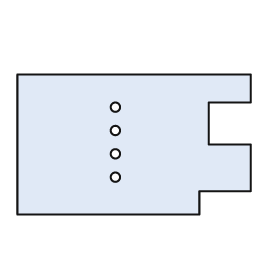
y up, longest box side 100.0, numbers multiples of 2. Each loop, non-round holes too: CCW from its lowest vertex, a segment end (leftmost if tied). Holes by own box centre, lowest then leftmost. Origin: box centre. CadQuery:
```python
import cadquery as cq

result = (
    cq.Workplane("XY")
    .moveTo(-50.0, -30.0)
    .lineTo(28.0, -30.0)
    .lineTo(28.0, -20.0)
    .lineTo(50.0, -20.0)
    .lineTo(50.0, 0.0)
    .lineTo(32.0, 0.0)
    .lineTo(32.0, 18.0)
    .lineTo(50.0, 18.0)
    .lineTo(50.0, 30.0)
    .lineTo(-50.0, 30.0)
    .close()
    .moveTo(-8.0, -14.0)
    .circle(2.0)
    .moveTo(-8.0, -4.0)
    .circle(2.0)
    .moveTo(-8.0, 6.0)
    .circle(2.0)
    .moveTo(-8.0, 16.0)
    .circle(2.0)
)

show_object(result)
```